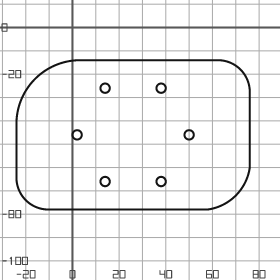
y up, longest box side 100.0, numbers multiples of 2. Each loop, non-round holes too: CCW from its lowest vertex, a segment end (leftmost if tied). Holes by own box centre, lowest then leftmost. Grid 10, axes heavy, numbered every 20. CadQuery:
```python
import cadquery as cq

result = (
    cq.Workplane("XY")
    .moveTo(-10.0, -78.0)
    .lineTo(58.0, -78.0)
    .threePointArc((70.0, -72.0), (76.0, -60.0))
    .lineTo(76.0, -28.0)
    .threePointArc((72.0, -18.0), (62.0, -14.0))
    .lineTo(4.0, -14.0)
    .threePointArc((-16.0, -22.0), (-24.0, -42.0))
    .lineTo(-24.0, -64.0)
    .threePointArc((-20.0, -74.0), (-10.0, -78.0))
    .close()
    .moveTo(14.0, -66.0)
    .circle(2.0)
    .moveTo(38.0, -66.0)
    .circle(2.0)
    .moveTo(2.0, -46.0)
    .circle(2.0)
    .moveTo(50.0, -46.0)
    .circle(2.0)
    .moveTo(14.0, -26.0)
    .circle(2.0)
    .moveTo(38.0, -26.0)
    .circle(2.0)
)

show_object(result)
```